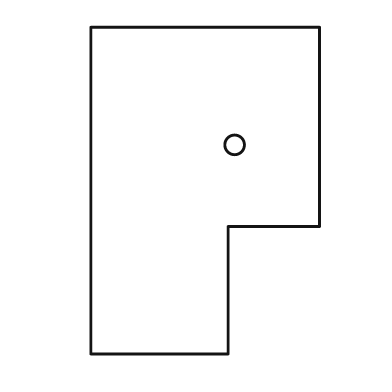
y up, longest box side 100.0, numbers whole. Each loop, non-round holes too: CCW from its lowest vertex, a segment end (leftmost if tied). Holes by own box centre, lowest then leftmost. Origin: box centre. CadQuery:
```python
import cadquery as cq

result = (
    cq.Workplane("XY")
    .moveTo(-35.0, -50.0)
    .lineTo(7.0, -50.0)
    .lineTo(7.0, -11.0)
    .lineTo(35.0, -11.0)
    .lineTo(35.0, 50.0)
    .lineTo(-35.0, 50.0)
    .close()
    .moveTo(9.0, 14.0)
    .circle(3.0)
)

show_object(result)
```